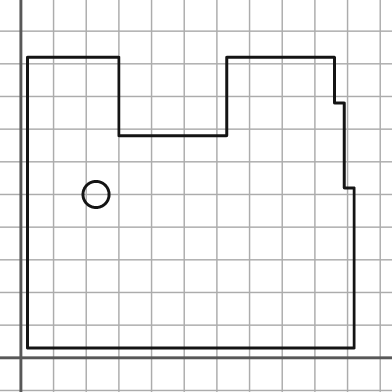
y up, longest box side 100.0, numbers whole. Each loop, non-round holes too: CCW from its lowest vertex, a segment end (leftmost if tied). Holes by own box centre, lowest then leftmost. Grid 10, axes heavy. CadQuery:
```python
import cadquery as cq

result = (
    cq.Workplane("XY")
    .moveTo(2.0, 3.0)
    .lineTo(102.0, 3.0)
    .lineTo(102.0, 52.0)
    .lineTo(99.0, 52.0)
    .lineTo(99.0, 78.0)
    .lineTo(96.0, 78.0)
    .lineTo(96.0, 92.0)
    .lineTo(63.0, 92.0)
    .lineTo(63.0, 68.0)
    .lineTo(30.0, 68.0)
    .lineTo(30.0, 92.0)
    .lineTo(2.0, 92.0)
    .close()
    .moveTo(23.0, 50.0)
    .circle(4.0)
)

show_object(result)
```